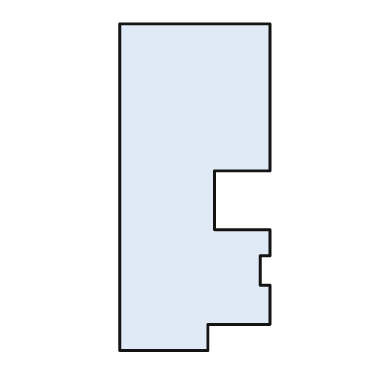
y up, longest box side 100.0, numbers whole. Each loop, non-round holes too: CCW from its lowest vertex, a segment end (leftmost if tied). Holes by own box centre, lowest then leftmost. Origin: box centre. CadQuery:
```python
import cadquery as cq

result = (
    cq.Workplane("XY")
    .moveTo(-23.0, -50.0)
    .lineTo(4.0, -50.0)
    .lineTo(4.0, -42.0)
    .lineTo(23.0, -42.0)
    .lineTo(23.0, -30.0)
    .lineTo(20.0, -30.0)
    .lineTo(20.0, -21.0)
    .lineTo(23.0, -21.0)
    .lineTo(23.0, -13.0)
    .lineTo(6.0, -13.0)
    .lineTo(6.0, 5.0)
    .lineTo(23.0, 5.0)
    .lineTo(23.0, 50.0)
    .lineTo(-23.0, 50.0)
    .close()
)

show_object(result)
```